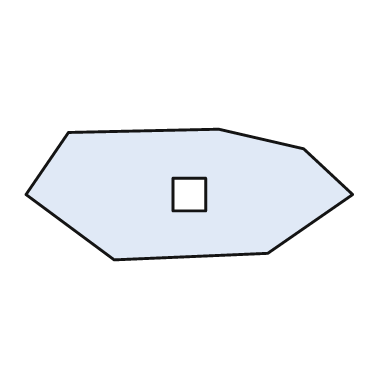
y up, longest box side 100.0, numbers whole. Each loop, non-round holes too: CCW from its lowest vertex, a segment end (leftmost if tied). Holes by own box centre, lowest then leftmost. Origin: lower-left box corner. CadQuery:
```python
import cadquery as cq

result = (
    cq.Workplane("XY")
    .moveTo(27.0, 0.0)
    .lineTo(74.0, 2.0)
    .lineTo(100.0, 20.0)
    .lineTo(85.0, 34.0)
    .lineTo(59.0, 40.0)
    .lineTo(13.0, 39.0)
    .lineTo(0.0, 20.0)
    .close()
    .moveTo(45.0, 15.0)
    .lineTo(55.0, 15.0)
    .lineTo(55.0, 25.0)
    .lineTo(45.0, 25.0)
    .close()
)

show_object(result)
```